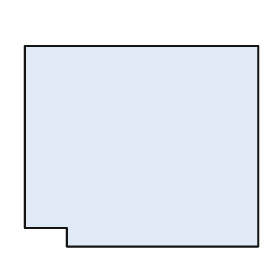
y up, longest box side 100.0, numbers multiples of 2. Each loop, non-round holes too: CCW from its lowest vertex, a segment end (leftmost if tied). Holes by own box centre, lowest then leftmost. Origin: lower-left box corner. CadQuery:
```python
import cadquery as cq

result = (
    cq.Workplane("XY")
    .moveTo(18.0, 0.0)
    .lineTo(100.0, 0.0)
    .lineTo(100.0, 86.0)
    .lineTo(0.0, 86.0)
    .lineTo(0.0, 8.0)
    .lineTo(18.0, 8.0)
    .close()
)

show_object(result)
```